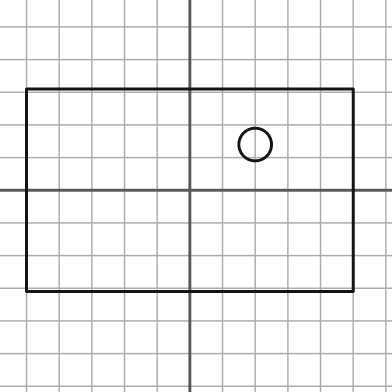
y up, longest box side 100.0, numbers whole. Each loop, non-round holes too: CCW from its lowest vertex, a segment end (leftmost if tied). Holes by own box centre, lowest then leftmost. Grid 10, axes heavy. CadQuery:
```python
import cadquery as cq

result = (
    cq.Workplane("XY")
    .moveTo(-50.0, -31.0)
    .lineTo(50.0, -31.0)
    .lineTo(50.0, 31.0)
    .lineTo(-50.0, 31.0)
    .close()
    .moveTo(20.0, 14.0)
    .circle(5.0)
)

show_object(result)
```